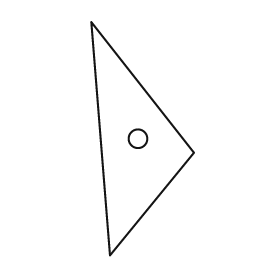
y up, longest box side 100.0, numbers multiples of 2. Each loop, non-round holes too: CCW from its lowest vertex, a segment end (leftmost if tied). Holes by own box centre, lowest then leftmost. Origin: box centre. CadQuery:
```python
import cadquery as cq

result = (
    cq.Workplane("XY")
    .moveTo(-14.0, -50.0)
    .lineTo(22.0, -6.0)
    .lineTo(-22.0, 50.0)
    .close()
    .moveTo(-2.0, 0.0)
    .circle(4.0)
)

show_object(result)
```